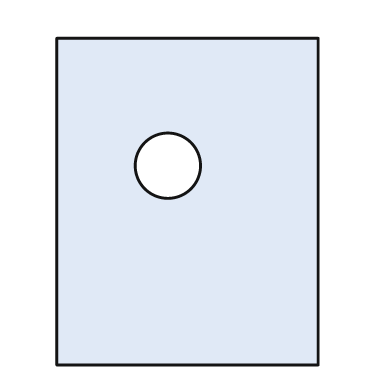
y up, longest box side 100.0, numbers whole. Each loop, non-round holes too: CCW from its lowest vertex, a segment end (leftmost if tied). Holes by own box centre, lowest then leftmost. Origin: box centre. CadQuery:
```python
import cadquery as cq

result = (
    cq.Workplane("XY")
    .moveTo(-40.0, -50.0)
    .lineTo(40.0, -50.0)
    .lineTo(40.0, 50.0)
    .lineTo(-40.0, 50.0)
    .close()
    .moveTo(-6.0, 11.0)
    .circle(10.0)
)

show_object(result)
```